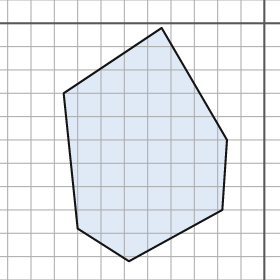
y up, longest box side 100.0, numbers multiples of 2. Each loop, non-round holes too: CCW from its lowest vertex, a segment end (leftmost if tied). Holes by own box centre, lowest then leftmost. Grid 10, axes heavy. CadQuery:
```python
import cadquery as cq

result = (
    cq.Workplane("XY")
    .moveTo(-58.0, -102.0)
    .lineTo(-18.0, -80.0)
    .lineTo(-16.0, -50.0)
    .lineTo(-44.0, -2.0)
    .lineTo(-86.0, -30.0)
    .lineTo(-80.0, -88.0)
    .close()
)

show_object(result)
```